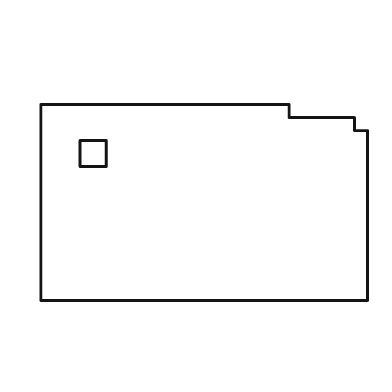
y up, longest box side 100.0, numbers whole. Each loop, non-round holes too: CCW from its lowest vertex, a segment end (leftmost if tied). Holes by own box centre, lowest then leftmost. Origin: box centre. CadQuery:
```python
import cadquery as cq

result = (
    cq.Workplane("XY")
    .moveTo(-50.0, -30.0)
    .lineTo(50.0, -30.0)
    .lineTo(50.0, 22.0)
    .lineTo(46.0, 22.0)
    .lineTo(46.0, 26.0)
    .lineTo(26.0, 26.0)
    .lineTo(26.0, 30.0)
    .lineTo(-50.0, 30.0)
    .close()
    .moveTo(-38.0, 11.0)
    .lineTo(-30.0, 11.0)
    .lineTo(-30.0, 19.0)
    .lineTo(-38.0, 19.0)
    .close()
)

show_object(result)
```